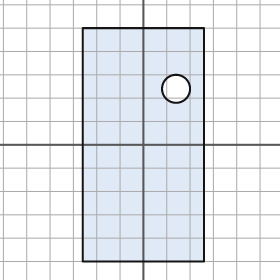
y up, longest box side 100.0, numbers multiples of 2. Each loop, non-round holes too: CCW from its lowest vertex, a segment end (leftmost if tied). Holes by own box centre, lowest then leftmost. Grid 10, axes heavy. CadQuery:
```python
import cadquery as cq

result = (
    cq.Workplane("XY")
    .moveTo(-26.0, -50.0)
    .lineTo(26.0, -50.0)
    .lineTo(26.0, 50.0)
    .lineTo(-26.0, 50.0)
    .close()
    .moveTo(14.0, 24.0)
    .circle(6.0)
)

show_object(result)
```